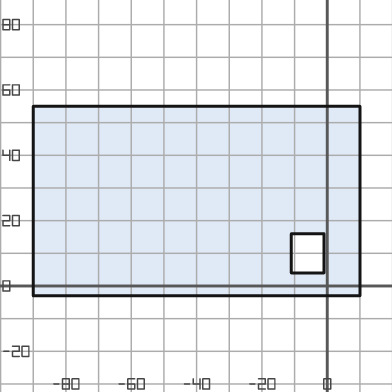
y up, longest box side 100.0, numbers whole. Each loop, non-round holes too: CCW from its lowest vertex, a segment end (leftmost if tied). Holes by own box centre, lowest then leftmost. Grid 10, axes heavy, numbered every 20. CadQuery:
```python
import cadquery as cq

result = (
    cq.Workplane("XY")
    .moveTo(-90.0, -3.0)
    .lineTo(10.0, -3.0)
    .lineTo(10.0, 55.0)
    .lineTo(-90.0, 55.0)
    .close()
    .moveTo(-11.0, 4.0)
    .lineTo(-1.0, 4.0)
    .lineTo(-1.0, 16.0)
    .lineTo(-11.0, 16.0)
    .close()
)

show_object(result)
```